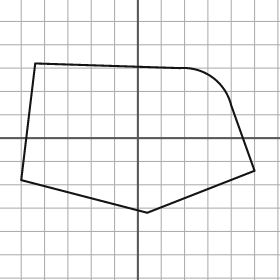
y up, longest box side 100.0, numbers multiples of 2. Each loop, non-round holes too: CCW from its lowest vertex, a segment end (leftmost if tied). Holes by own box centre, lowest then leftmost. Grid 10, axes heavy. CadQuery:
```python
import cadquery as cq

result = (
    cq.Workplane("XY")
    .moveTo(4.0, -32.0)
    .lineTo(50.0, -14.0)
    .lineTo(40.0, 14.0)
    .threePointArc((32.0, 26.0), (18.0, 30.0))
    .lineTo(-44.0, 32.0)
    .lineTo(-50.0, -18.0)
    .close()
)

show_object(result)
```